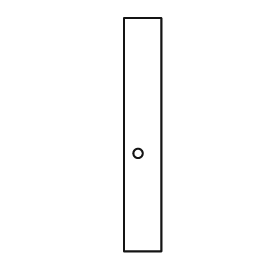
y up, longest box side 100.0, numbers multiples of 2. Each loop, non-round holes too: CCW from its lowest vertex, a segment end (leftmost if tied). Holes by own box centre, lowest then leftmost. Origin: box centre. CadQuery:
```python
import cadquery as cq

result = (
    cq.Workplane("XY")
    .moveTo(-8.0, -50.0)
    .lineTo(8.0, -50.0)
    .lineTo(8.0, 50.0)
    .lineTo(-8.0, 50.0)
    .close()
    .moveTo(-2.0, -8.0)
    .circle(2.0)
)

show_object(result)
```